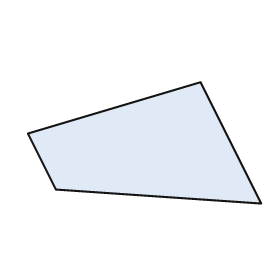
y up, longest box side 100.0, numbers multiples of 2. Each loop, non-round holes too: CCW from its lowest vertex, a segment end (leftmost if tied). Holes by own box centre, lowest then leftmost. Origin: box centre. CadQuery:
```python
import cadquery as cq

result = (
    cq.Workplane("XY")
    .moveTo(50.0, -26.0)
    .lineTo(24.0, 26.0)
    .lineTo(-50.0, 4.0)
    .lineTo(-38.0, -20.0)
    .close()
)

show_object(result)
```